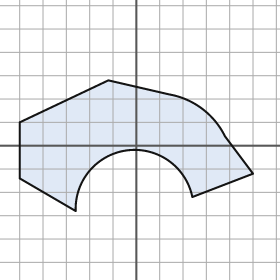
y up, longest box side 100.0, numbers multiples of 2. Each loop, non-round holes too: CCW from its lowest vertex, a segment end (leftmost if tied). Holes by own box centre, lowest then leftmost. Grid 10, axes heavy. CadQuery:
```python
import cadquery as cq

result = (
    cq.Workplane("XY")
    .moveTo(-26.0, -28.0)
    .threePointArc((-4.0, -2.0), (24.0, -22.0))
    .lineTo(50.0, -12.0)
    .lineTo(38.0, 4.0)
    .threePointArc((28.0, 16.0), (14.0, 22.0))
    .lineTo(-12.0, 28.0)
    .lineTo(-50.0, 10.0)
    .lineTo(-50.0, -14.0)
    .close()
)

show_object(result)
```